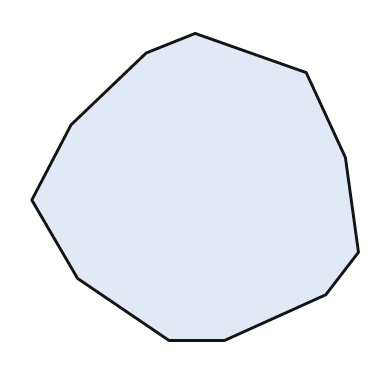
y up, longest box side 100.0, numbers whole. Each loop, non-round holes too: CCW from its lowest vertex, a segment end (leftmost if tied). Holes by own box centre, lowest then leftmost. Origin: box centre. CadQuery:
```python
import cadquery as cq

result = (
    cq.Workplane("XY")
    .moveTo(-8.0, -47.0)
    .lineTo(9.0, -47.0)
    .lineTo(40.0, -33.0)
    .lineTo(50.0, -20.0)
    .lineTo(46.0, 9.0)
    .lineTo(34.0, 35.0)
    .lineTo(0.0, 47.0)
    .lineTo(-15.0, 41.0)
    .lineTo(-38.0, 19.0)
    .lineTo(-50.0, -4.0)
    .lineTo(-36.0, -28.0)
    .close()
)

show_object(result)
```